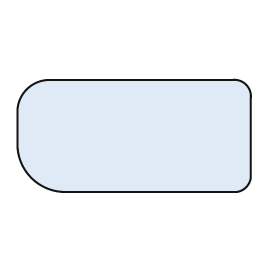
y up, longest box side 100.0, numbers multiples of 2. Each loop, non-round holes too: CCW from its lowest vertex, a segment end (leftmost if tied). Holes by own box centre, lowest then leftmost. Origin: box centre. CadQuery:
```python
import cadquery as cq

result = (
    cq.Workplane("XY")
    .moveTo(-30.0, -24.0)
    .lineTo(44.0, -24.0)
    .threePointArc((48.0, -22.0), (50.0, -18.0))
    .lineTo(50.0, 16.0)
    .threePointArc((48.0, 22.0), (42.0, 24.0))
    .lineTo(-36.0, 24.0)
    .threePointArc((-46.0, 20.0), (-50.0, 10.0))
    .lineTo(-50.0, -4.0)
    .threePointArc((-44.0, -18.0), (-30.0, -24.0))
    .close()
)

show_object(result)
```